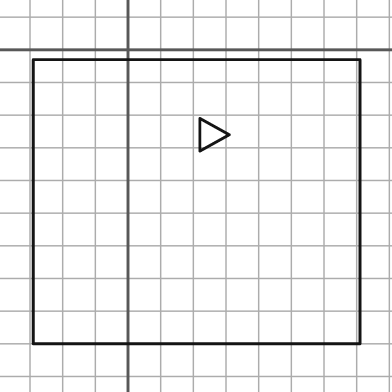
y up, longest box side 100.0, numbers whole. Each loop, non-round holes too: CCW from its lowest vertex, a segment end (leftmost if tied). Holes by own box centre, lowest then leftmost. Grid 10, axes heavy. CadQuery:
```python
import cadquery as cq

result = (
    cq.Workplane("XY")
    .moveTo(-29.0, -90.0)
    .lineTo(71.0, -90.0)
    .lineTo(71.0, -3.0)
    .lineTo(-29.0, -3.0)
    .close()
    .moveTo(22.0, -31.0)
    .lineTo(31.0, -26.0)
    .lineTo(22.0, -21.0)
    .close()
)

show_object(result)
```